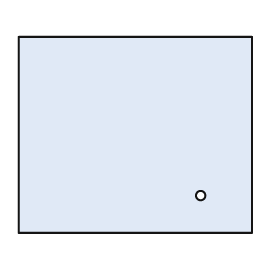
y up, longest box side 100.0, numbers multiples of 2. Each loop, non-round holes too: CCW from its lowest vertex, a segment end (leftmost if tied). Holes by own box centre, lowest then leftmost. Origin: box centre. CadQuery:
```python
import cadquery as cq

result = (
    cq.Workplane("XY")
    .moveTo(-50.0, -42.0)
    .lineTo(50.0, -42.0)
    .lineTo(50.0, 42.0)
    .lineTo(-50.0, 42.0)
    .close()
    .moveTo(28.0, -26.0)
    .circle(2.0)
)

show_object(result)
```